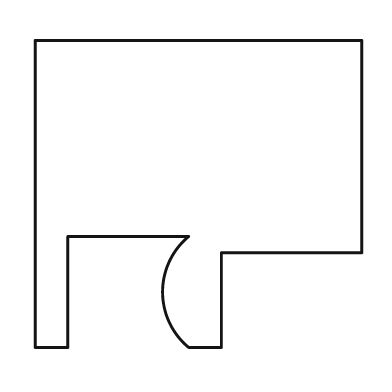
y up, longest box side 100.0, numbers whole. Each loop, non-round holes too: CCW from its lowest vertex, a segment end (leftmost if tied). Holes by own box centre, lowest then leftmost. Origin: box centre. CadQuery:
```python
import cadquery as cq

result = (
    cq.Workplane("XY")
    .moveTo(-50.0, -47.0)
    .lineTo(-40.0, -47.0)
    .lineTo(-40.0, -13.0)
    .lineTo(-3.0, -13.0)
    .threePointArc((-11.0, -30.0), (-3.0, -47.0))
    .lineTo(7.0, -47.0)
    .lineTo(7.0, -18.0)
    .lineTo(50.0, -18.0)
    .lineTo(50.0, 47.0)
    .lineTo(-50.0, 47.0)
    .close()
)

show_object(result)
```